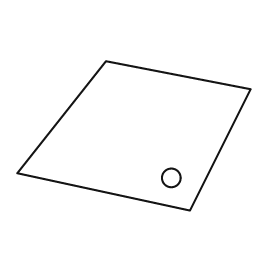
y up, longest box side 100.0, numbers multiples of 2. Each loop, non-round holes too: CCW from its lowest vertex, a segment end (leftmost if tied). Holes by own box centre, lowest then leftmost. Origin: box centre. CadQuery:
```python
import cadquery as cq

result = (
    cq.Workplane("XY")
    .moveTo(24.0, -32.0)
    .lineTo(50.0, 20.0)
    .lineTo(-12.0, 32.0)
    .lineTo(-50.0, -16.0)
    .close()
    .moveTo(16.0, -18.0)
    .circle(4.0)
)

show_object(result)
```